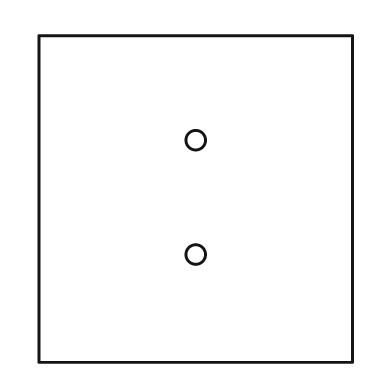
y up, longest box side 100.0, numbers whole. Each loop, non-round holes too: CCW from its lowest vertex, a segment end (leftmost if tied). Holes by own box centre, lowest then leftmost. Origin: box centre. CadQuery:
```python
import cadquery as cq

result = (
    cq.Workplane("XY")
    .moveTo(-48.0, -50.0)
    .lineTo(48.0, -50.0)
    .lineTo(48.0, 50.0)
    .lineTo(-48.0, 50.0)
    .close()
    .moveTo(0.0, -17.0)
    .circle(3.0)
    .moveTo(0.0, 18.0)
    .circle(3.0)
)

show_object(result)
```